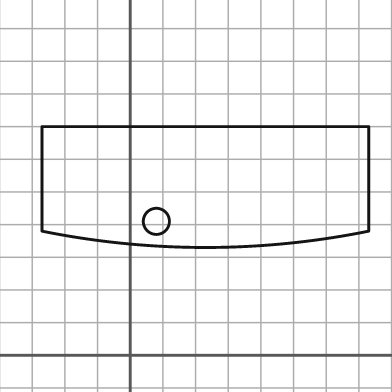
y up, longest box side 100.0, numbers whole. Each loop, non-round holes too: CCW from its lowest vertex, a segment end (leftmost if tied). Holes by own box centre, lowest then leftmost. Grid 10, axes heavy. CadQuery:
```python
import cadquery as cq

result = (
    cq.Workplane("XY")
    .moveTo(-27.0, 38.0)
    .threePointArc((23.0, 33.0), (73.0, 38.0))
    .lineTo(73.0, 70.0)
    .lineTo(-27.0, 70.0)
    .close()
    .moveTo(8.0, 41.0)
    .circle(4.0)
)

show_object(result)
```